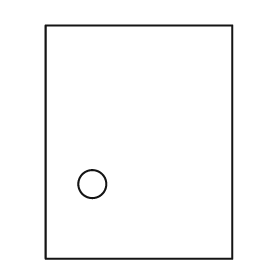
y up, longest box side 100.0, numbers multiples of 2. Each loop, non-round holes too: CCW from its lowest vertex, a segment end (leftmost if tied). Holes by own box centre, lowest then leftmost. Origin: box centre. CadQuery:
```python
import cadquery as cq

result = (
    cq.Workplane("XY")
    .moveTo(-40.0, -50.0)
    .lineTo(40.0, -50.0)
    .lineTo(40.0, 50.0)
    .lineTo(-40.0, 50.0)
    .close()
    .moveTo(-20.0, -18.0)
    .circle(6.0)
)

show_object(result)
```